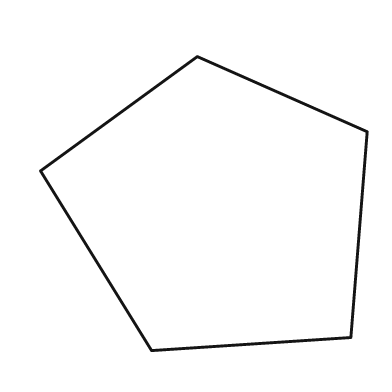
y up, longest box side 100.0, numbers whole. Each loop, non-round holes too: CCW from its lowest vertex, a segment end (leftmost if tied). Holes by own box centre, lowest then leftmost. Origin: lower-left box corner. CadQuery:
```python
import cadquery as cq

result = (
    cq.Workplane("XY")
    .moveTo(34.0, 0.0)
    .lineTo(95.0, 4.0)
    .lineTo(100.0, 67.0)
    .lineTo(48.0, 90.0)
    .lineTo(0.0, 55.0)
    .close()
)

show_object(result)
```